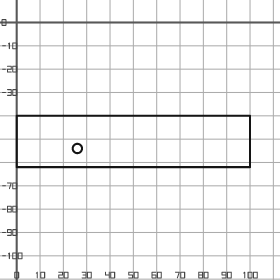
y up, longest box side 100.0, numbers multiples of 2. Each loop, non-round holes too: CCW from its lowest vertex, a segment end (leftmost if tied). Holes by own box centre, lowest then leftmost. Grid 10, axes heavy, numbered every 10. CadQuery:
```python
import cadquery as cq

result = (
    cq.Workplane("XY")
    .moveTo(0.0, -62.0)
    .lineTo(100.0, -62.0)
    .lineTo(100.0, -40.0)
    .lineTo(0.0, -40.0)
    .close()
    .moveTo(26.0, -54.0)
    .circle(2.0)
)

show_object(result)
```